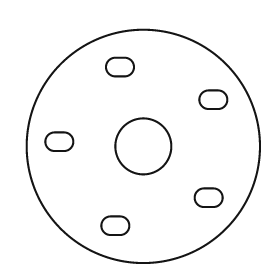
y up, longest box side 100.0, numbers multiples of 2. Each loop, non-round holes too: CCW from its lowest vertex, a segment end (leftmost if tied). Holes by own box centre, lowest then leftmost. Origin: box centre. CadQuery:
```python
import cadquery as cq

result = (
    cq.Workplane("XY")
    .moveTo(0.0, 0.0)
    .circle(50.0)
    .moveTo(-14.0, -38.0)
    .lineTo(-10.0, -38.0)
    .threePointArc((-6.0, -34.0), (-10.0, -30.0))
    .lineTo(-14.0, -30.0)
    .threePointArc((-18.0, -34.0), (-14.0, -38.0))
    .close()
    .moveTo(26.0, -26.0)
    .lineTo(30.0, -26.0)
    .threePointArc((34.0, -22.0), (30.0, -18.0))
    .lineTo(26.0, -18.0)
    .threePointArc((22.0, -22.0), (26.0, -26.0))
    .close()
    .moveTo(0.0, 0.0)
    .circle(12.0)
    .moveTo(-38.0, -2.0)
    .lineTo(-34.0, -2.0)
    .threePointArc((-30.0, 2.0), (-34.0, 6.0))
    .lineTo(-38.0, 6.0)
    .threePointArc((-42.0, 2.0), (-38.0, -2.0))
    .close()
    .moveTo(28.0, 16.0)
    .lineTo(32.0, 16.0)
    .threePointArc((36.0, 20.0), (32.0, 24.0))
    .lineTo(28.0, 24.0)
    .threePointArc((24.0, 20.0), (28.0, 16.0))
    .close()
    .moveTo(-12.0, 30.0)
    .lineTo(-8.0, 30.0)
    .threePointArc((-4.0, 34.0), (-8.0, 38.0))
    .lineTo(-12.0, 38.0)
    .threePointArc((-16.0, 34.0), (-12.0, 30.0))
    .close()
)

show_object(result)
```